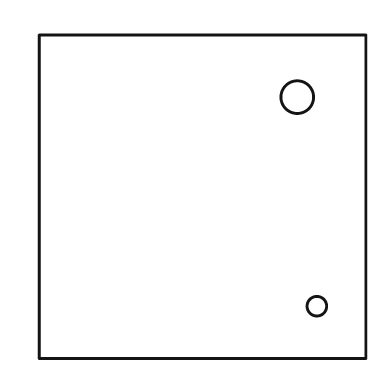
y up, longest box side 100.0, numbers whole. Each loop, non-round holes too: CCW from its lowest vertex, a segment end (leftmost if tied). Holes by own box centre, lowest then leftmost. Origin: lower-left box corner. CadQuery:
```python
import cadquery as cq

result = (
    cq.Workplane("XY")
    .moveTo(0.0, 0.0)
    .lineTo(100.0, 0.0)
    .lineTo(100.0, 99.0)
    .lineTo(0.0, 99.0)
    .close()
    .moveTo(85.0, 16.0)
    .circle(3.0)
    .moveTo(79.0, 80.0)
    .circle(5.0)
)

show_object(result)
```